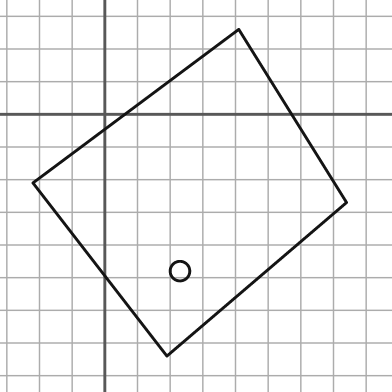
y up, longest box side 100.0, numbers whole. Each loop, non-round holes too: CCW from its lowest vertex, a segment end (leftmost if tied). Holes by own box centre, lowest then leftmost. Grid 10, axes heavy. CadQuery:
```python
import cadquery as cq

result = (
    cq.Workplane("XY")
    .moveTo(19.0, -74.0)
    .lineTo(74.0, -27.0)
    .lineTo(41.0, 26.0)
    .lineTo(-22.0, -21.0)
    .close()
    .moveTo(23.0, -48.0)
    .circle(3.0)
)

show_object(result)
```